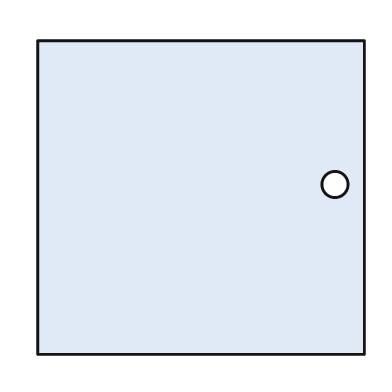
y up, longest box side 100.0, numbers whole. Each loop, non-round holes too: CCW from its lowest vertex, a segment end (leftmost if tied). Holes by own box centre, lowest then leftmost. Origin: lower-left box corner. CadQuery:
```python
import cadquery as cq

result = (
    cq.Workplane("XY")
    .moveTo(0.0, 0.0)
    .lineTo(100.0, 0.0)
    .lineTo(100.0, 96.0)
    .lineTo(0.0, 96.0)
    .close()
    .moveTo(91.0, 52.0)
    .circle(4.0)
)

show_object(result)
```